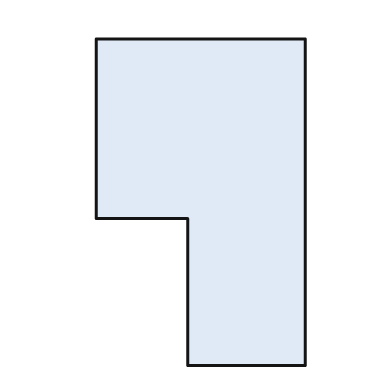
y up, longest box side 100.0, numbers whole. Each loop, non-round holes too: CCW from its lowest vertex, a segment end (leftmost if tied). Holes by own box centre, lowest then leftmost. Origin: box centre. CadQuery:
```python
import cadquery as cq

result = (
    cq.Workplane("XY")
    .moveTo(-4.0, -50.0)
    .lineTo(32.0, -50.0)
    .lineTo(32.0, 50.0)
    .lineTo(-32.0, 50.0)
    .lineTo(-32.0, -5.0)
    .lineTo(-4.0, -5.0)
    .close()
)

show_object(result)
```